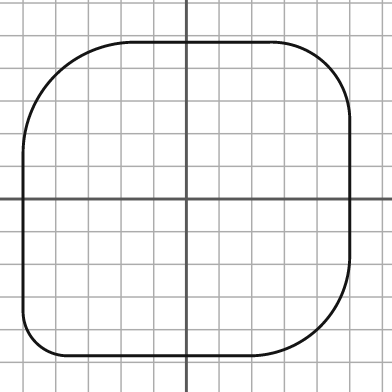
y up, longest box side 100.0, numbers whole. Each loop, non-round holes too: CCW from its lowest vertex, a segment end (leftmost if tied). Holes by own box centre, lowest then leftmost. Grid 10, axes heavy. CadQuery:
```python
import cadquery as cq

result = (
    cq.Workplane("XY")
    .moveTo(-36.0, -48.0)
    .lineTo(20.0, -48.0)
    .threePointArc((41.0, -39.0), (50.0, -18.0))
    .lineTo(50.0, 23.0)
    .threePointArc((43.0, 41.0), (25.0, 48.0))
    .lineTo(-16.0, 48.0)
    .threePointArc((-40.0, 38.0), (-50.0, 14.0))
    .lineTo(-50.0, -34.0)
    .threePointArc((-46.0, -44.0), (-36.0, -48.0))
    .close()
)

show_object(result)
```